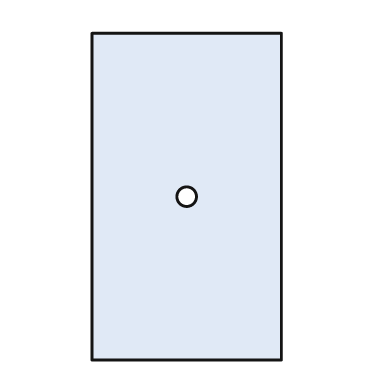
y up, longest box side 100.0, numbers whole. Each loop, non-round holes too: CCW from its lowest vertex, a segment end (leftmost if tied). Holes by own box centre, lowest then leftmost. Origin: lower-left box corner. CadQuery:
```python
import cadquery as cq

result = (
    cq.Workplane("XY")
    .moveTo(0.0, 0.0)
    .lineTo(58.0, 0.0)
    .lineTo(58.0, 100.0)
    .lineTo(0.0, 100.0)
    .close()
    .moveTo(29.0, 50.0)
    .circle(3.0)
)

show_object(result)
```